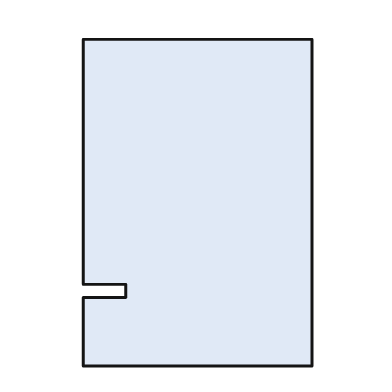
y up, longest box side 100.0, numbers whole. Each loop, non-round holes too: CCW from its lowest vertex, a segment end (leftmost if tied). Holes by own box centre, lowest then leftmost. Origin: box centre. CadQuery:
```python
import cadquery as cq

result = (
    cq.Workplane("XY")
    .moveTo(-35.0, -50.0)
    .lineTo(35.0, -50.0)
    .lineTo(35.0, 50.0)
    .lineTo(-35.0, 50.0)
    .lineTo(-35.0, -25.0)
    .lineTo(-22.0, -25.0)
    .lineTo(-22.0, -29.0)
    .lineTo(-35.0, -29.0)
    .close()
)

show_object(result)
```